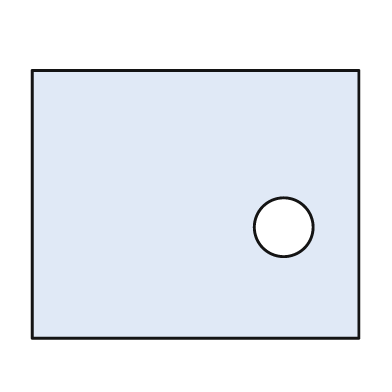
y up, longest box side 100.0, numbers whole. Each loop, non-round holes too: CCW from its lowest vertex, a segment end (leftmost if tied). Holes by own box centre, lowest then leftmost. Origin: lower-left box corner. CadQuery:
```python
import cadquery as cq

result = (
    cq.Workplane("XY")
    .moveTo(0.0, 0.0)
    .lineTo(100.0, 0.0)
    .lineTo(100.0, 82.0)
    .lineTo(0.0, 82.0)
    .close()
    .moveTo(77.0, 34.0)
    .circle(9.0)
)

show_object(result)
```